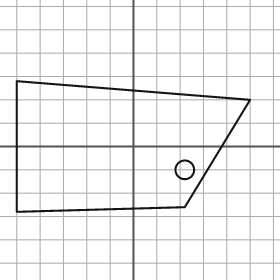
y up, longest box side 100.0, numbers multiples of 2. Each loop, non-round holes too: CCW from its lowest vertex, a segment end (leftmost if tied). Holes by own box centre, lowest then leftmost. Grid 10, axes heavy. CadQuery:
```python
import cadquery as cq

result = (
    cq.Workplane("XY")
    .moveTo(-50.0, -28.0)
    .lineTo(22.0, -26.0)
    .lineTo(50.0, 20.0)
    .lineTo(-50.0, 28.0)
    .close()
    .moveTo(22.0, -10.0)
    .circle(4.0)
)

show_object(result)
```